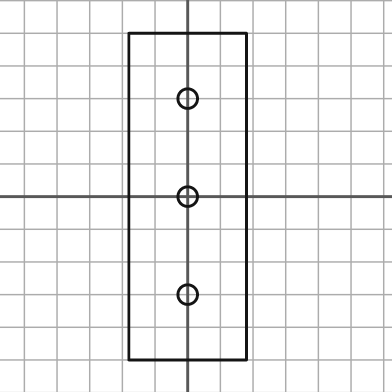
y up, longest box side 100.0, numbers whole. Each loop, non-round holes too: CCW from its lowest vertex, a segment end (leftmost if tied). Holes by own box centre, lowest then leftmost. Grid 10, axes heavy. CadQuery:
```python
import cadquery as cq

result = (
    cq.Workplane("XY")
    .moveTo(-18.0, -50.0)
    .lineTo(18.0, -50.0)
    .lineTo(18.0, 50.0)
    .lineTo(-18.0, 50.0)
    .close()
    .moveTo(0.0, -30.0)
    .circle(3.0)
    .moveTo(0.0, 0.0)
    .circle(3.0)
    .moveTo(0.0, 30.0)
    .circle(3.0)
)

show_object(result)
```